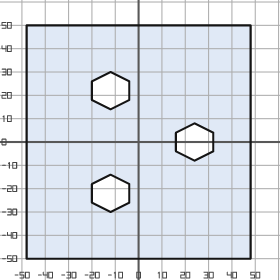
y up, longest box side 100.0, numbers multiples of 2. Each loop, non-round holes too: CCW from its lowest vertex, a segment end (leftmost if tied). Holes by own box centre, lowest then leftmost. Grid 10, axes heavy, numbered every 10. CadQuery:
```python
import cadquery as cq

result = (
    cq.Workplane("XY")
    .moveTo(-48.0, -50.0)
    .lineTo(48.0, -50.0)
    .lineTo(48.0, 50.0)
    .lineTo(-48.0, 50.0)
    .close()
    .moveTo(-12.0, -30.0)
    .lineTo(-4.0, -26.0)
    .lineTo(-4.0, -18.0)
    .lineTo(-12.0, -14.0)
    .lineTo(-20.0, -18.0)
    .lineTo(-20.0, -26.0)
    .close()
    .moveTo(24.0, -8.0)
    .lineTo(32.0, -4.0)
    .lineTo(32.0, 4.0)
    .lineTo(24.0, 8.0)
    .lineTo(16.0, 4.0)
    .lineTo(16.0, -4.0)
    .close()
    .moveTo(-12.0, 14.0)
    .lineTo(-4.0, 18.0)
    .lineTo(-4.0, 26.0)
    .lineTo(-12.0, 30.0)
    .lineTo(-20.0, 26.0)
    .lineTo(-20.0, 18.0)
    .close()
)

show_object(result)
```